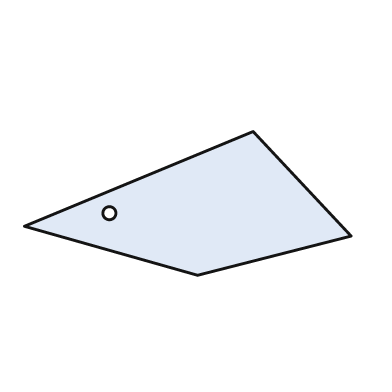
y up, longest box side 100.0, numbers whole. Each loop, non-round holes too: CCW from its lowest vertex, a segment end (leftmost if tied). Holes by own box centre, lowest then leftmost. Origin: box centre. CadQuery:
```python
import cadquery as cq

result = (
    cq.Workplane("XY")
    .moveTo(3.0, -22.0)
    .lineTo(50.0, -10.0)
    .lineTo(20.0, 22.0)
    .lineTo(-50.0, -7.0)
    .close()
    .moveTo(-24.0, -3.0)
    .circle(2.0)
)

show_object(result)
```